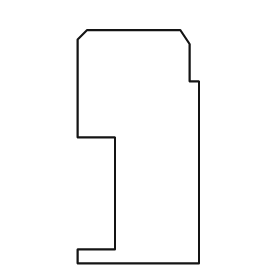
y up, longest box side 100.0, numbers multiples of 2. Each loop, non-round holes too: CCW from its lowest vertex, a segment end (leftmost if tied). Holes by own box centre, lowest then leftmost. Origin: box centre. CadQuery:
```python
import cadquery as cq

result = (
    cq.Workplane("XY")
    .moveTo(-26.0, -50.0)
    .lineTo(26.0, -50.0)
    .lineTo(26.0, 28.0)
    .lineTo(22.0, 28.0)
    .lineTo(22.0, 44.0)
    .lineTo(18.0, 50.0)
    .lineTo(-22.0, 50.0)
    .lineTo(-26.0, 46.0)
    .lineTo(-26.0, 4.0)
    .lineTo(-10.0, 4.0)
    .lineTo(-10.0, -44.0)
    .lineTo(-26.0, -44.0)
    .close()
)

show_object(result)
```